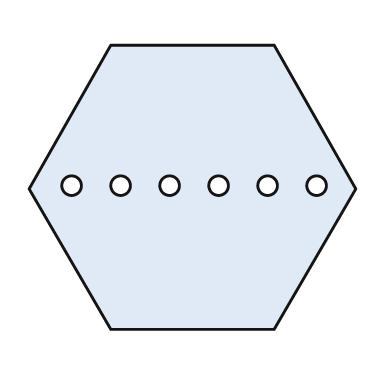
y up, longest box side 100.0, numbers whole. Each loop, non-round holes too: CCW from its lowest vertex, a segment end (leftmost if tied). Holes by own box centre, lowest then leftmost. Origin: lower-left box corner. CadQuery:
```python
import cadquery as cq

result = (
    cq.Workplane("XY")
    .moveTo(25.0, 0.0)
    .lineTo(75.0, 0.0)
    .lineTo(100.0, 43.0)
    .lineTo(75.0, 87.0)
    .lineTo(25.0, 87.0)
    .lineTo(0.0, 43.0)
    .close()
    .moveTo(13.0, 44.0)
    .circle(3.0)
    .moveTo(28.0, 44.0)
    .circle(3.0)
    .moveTo(43.0, 44.0)
    .circle(3.0)
    .moveTo(58.0, 44.0)
    .circle(3.0)
    .moveTo(73.0, 44.0)
    .circle(3.0)
    .moveTo(88.0, 44.0)
    .circle(3.0)
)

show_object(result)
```